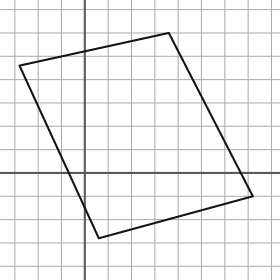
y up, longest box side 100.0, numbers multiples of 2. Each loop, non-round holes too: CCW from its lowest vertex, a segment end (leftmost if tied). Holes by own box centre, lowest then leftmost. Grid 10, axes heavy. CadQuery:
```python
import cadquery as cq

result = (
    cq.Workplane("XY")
    .moveTo(6.0, -28.0)
    .lineTo(72.0, -10.0)
    .lineTo(36.0, 60.0)
    .lineTo(-28.0, 46.0)
    .close()
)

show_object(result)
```